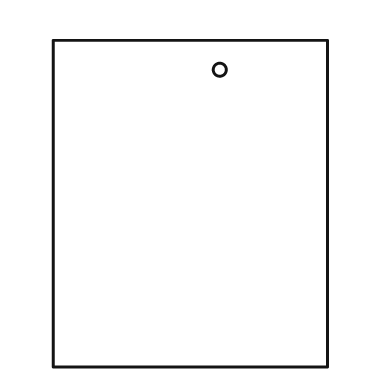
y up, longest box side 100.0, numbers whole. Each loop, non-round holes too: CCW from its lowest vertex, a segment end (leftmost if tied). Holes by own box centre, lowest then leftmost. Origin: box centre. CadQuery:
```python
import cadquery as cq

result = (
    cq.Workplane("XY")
    .moveTo(-42.0, -50.0)
    .lineTo(42.0, -50.0)
    .lineTo(42.0, 50.0)
    .lineTo(-42.0, 50.0)
    .close()
    .moveTo(9.0, 41.0)
    .circle(2.0)
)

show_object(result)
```